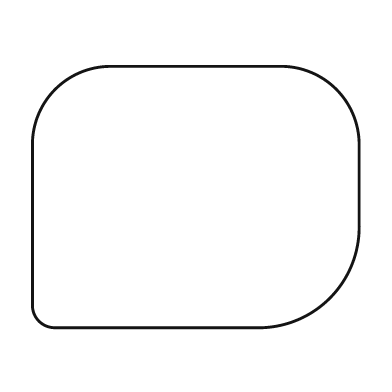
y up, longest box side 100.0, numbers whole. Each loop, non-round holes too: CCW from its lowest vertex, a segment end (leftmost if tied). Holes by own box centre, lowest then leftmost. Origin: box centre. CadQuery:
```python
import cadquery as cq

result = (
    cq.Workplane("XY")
    .moveTo(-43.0, -40.0)
    .lineTo(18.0, -40.0)
    .threePointArc((41.0, -31.0), (50.0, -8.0))
    .lineTo(50.0, 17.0)
    .threePointArc((43.0, 33.0), (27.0, 40.0))
    .lineTo(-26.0, 40.0)
    .threePointArc((-43.0, 33.0), (-50.0, 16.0))
    .lineTo(-50.0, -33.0)
    .threePointArc((-48.0, -38.0), (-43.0, -40.0))
    .close()
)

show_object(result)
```